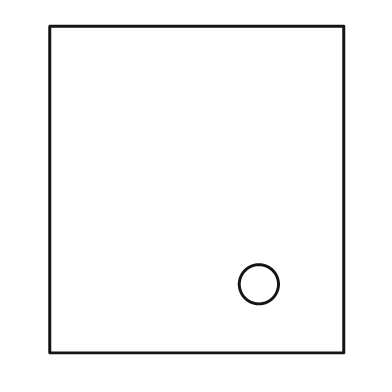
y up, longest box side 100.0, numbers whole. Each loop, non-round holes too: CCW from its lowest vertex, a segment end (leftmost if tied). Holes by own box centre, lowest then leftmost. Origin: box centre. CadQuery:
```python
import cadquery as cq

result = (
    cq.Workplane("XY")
    .moveTo(-45.0, -50.0)
    .lineTo(45.0, -50.0)
    .lineTo(45.0, 50.0)
    .lineTo(-45.0, 50.0)
    .close()
    .moveTo(19.0, -29.0)
    .circle(6.0)
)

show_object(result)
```